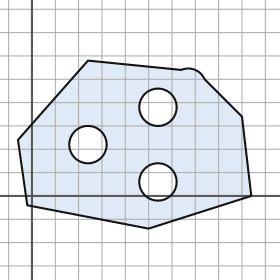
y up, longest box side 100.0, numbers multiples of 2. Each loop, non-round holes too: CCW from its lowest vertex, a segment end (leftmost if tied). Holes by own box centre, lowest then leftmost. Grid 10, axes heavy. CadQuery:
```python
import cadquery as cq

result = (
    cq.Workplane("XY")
    .moveTo(50.0, -14.0)
    .lineTo(94.0, 0.0)
    .lineTo(90.0, 34.0)
    .lineTo(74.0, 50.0)
    .threePointArc((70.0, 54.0), (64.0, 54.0))
    .lineTo(24.0, 58.0)
    .lineTo(-6.0, 24.0)
    .lineTo(-2.0, -4.0)
    .close()
    .moveTo(54.0, 6.0)
    .circle(8.0)
    .moveTo(24.0, 22.0)
    .circle(8.0)
    .moveTo(54.0, 38.0)
    .circle(8.0)
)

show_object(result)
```